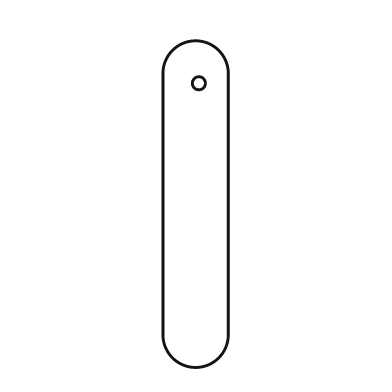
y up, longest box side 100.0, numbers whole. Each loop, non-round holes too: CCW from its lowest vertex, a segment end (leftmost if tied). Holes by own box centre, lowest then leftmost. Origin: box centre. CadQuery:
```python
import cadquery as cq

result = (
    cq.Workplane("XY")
    .moveTo(-10.0, -40.0)
    .threePointArc((0.0, -50.0), (10.0, -40.0))
    .lineTo(10.0, 40.0)
    .threePointArc((0.0, 50.0), (-10.0, 40.0))
    .close()
    .moveTo(1.0, 37.0)
    .circle(2.0)
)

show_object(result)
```